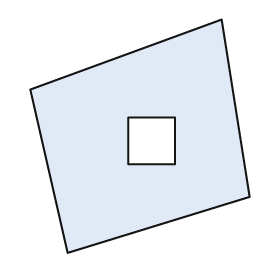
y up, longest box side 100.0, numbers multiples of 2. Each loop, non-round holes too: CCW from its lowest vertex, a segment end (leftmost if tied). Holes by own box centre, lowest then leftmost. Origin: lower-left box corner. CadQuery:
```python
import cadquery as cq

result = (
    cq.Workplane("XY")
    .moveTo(16.0, 0.0)
    .lineTo(94.0, 24.0)
    .lineTo(82.0, 100.0)
    .lineTo(0.0, 70.0)
    .close()
    .moveTo(42.0, 38.0)
    .lineTo(62.0, 38.0)
    .lineTo(62.0, 58.0)
    .lineTo(42.0, 58.0)
    .close()
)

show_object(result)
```